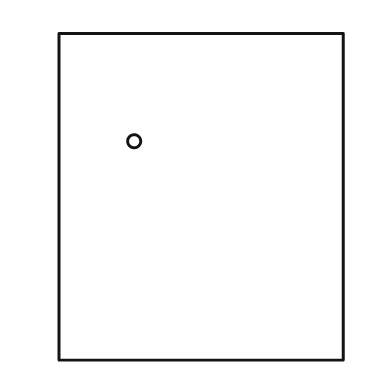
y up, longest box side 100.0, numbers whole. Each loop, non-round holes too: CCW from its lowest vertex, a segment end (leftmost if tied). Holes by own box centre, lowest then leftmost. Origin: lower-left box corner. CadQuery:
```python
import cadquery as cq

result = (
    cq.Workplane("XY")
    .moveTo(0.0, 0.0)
    .lineTo(87.0, 0.0)
    .lineTo(87.0, 100.0)
    .lineTo(0.0, 100.0)
    .close()
    .moveTo(23.0, 67.0)
    .circle(2.0)
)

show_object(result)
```